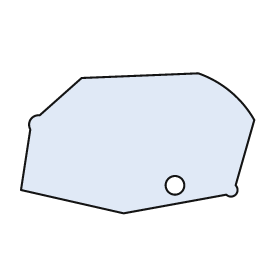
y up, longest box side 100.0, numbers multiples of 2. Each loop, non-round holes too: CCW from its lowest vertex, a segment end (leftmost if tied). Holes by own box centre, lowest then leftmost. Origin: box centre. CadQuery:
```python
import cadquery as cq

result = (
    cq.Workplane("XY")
    .moveTo(-6.0, -30.0)
    .lineTo(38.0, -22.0)
    .threePointArc((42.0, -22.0), (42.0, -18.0))
    .lineTo(50.0, 10.0)
    .threePointArc((40.0, 22.0), (26.0, 30.0))
    .lineTo(-24.0, 28.0)
    .lineTo(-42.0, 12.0)
    .threePointArc((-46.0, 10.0), (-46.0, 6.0))
    .lineTo(-50.0, -20.0)
    .close()
    .moveTo(16.0, -18.0)
    .circle(4.0)
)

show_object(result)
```